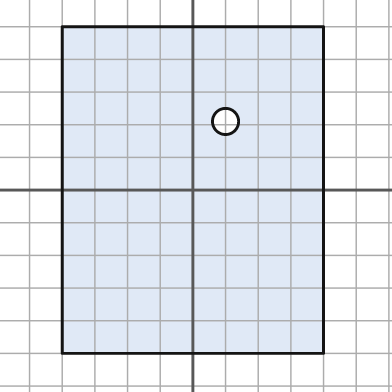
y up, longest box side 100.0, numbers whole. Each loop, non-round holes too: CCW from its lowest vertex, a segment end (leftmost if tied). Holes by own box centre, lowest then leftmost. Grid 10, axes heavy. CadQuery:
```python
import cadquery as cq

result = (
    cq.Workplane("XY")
    .moveTo(-40.0, -50.0)
    .lineTo(40.0, -50.0)
    .lineTo(40.0, 50.0)
    .lineTo(-40.0, 50.0)
    .close()
    .moveTo(10.0, 21.0)
    .circle(4.0)
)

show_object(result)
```